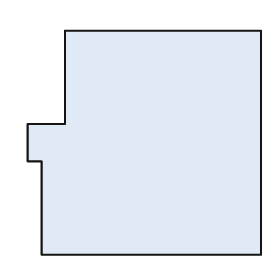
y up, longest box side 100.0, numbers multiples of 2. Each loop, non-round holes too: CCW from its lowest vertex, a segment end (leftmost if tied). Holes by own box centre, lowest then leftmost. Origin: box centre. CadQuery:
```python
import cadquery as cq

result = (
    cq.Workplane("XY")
    .moveTo(-44.0, -48.0)
    .lineTo(50.0, -48.0)
    .lineTo(50.0, 48.0)
    .lineTo(-34.0, 48.0)
    .lineTo(-34.0, 8.0)
    .lineTo(-50.0, 8.0)
    .lineTo(-50.0, -8.0)
    .lineTo(-44.0, -8.0)
    .close()
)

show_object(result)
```